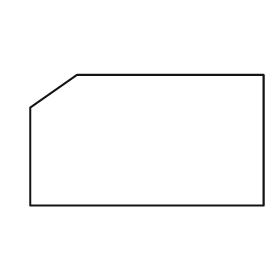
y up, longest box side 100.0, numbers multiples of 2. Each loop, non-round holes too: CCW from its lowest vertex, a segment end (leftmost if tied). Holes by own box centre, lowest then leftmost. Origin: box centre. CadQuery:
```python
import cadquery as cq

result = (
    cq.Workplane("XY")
    .moveTo(-50.0, -28.0)
    .lineTo(50.0, -28.0)
    .lineTo(50.0, 28.0)
    .lineTo(-30.0, 28.0)
    .lineTo(-50.0, 14.0)
    .close()
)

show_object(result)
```